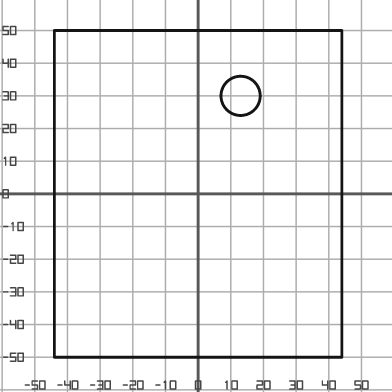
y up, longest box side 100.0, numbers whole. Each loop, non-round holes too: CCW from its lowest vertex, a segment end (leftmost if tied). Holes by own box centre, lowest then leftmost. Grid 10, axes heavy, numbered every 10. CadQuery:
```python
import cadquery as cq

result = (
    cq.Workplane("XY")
    .moveTo(-44.0, -50.0)
    .lineTo(44.0, -50.0)
    .lineTo(44.0, 50.0)
    .lineTo(-44.0, 50.0)
    .close()
    .moveTo(13.0, 30.0)
    .circle(6.0)
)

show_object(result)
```